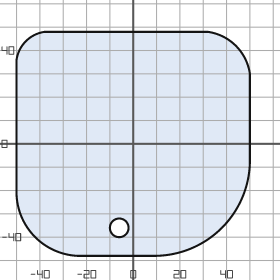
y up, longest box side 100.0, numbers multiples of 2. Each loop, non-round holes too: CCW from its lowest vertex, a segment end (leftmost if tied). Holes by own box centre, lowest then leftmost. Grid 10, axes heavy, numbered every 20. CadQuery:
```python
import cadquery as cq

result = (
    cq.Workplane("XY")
    .moveTo(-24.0, -48.0)
    .lineTo(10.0, -48.0)
    .threePointArc((38.0, -36.0), (50.0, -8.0))
    .lineTo(50.0, 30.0)
    .threePointArc((44.0, 42.0), (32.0, 48.0))
    .lineTo(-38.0, 48.0)
    .threePointArc((-46.0, 44.0), (-50.0, 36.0))
    .lineTo(-50.0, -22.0)
    .threePointArc((-42.0, -40.0), (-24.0, -48.0))
    .close()
    .moveTo(-6.0, -36.0)
    .circle(4.0)
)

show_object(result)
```